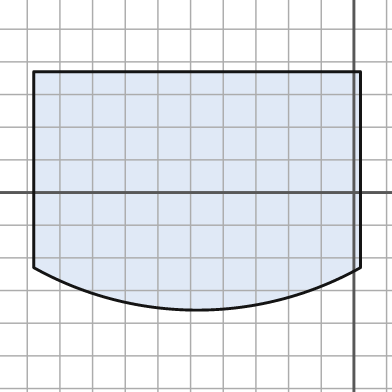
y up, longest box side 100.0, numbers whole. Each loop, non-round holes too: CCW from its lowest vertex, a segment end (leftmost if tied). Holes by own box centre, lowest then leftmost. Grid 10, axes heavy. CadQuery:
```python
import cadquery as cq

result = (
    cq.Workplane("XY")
    .moveTo(-98.0, -23.0)
    .threePointArc((-48.0, -36.0), (2.0, -23.0))
    .lineTo(2.0, 37.0)
    .lineTo(-98.0, 37.0)
    .close()
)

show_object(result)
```